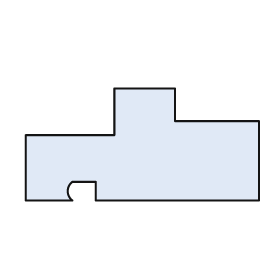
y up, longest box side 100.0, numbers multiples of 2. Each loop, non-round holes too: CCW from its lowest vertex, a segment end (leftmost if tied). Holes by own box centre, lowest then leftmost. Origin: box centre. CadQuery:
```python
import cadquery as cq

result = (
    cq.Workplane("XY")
    .moveTo(-50.0, -24.0)
    .lineTo(-30.0, -24.0)
    .threePointArc((-32.0, -20.0), (-30.0, -16.0))
    .lineTo(-20.0, -16.0)
    .lineTo(-20.0, -24.0)
    .lineTo(50.0, -24.0)
    .lineTo(50.0, 10.0)
    .lineTo(14.0, 10.0)
    .lineTo(14.0, 24.0)
    .lineTo(-12.0, 24.0)
    .lineTo(-12.0, 4.0)
    .lineTo(-50.0, 4.0)
    .close()
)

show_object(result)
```